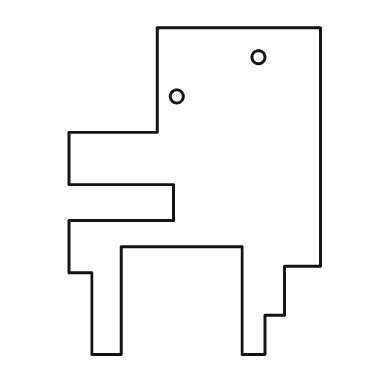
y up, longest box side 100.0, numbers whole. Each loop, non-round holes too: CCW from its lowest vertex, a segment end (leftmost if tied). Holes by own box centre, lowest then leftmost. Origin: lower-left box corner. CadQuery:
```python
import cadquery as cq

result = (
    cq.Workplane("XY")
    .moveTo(7.0, 0.0)
    .lineTo(16.0, 0.0)
    .lineTo(16.0, 33.0)
    .lineTo(53.0, 33.0)
    .lineTo(53.0, 0.0)
    .lineTo(60.0, 0.0)
    .lineTo(60.0, 12.0)
    .lineTo(66.0, 12.0)
    .lineTo(66.0, 27.0)
    .lineTo(77.0, 27.0)
    .lineTo(77.0, 100.0)
    .lineTo(27.0, 100.0)
    .lineTo(27.0, 68.0)
    .lineTo(0.0, 68.0)
    .lineTo(0.0, 52.0)
    .lineTo(32.0, 52.0)
    .lineTo(32.0, 41.0)
    .lineTo(0.0, 41.0)
    .lineTo(0.0, 25.0)
    .lineTo(7.0, 25.0)
    .close()
    .moveTo(33.0, 79.0)
    .circle(2.0)
    .moveTo(58.0, 91.0)
    .circle(2.0)
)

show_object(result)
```